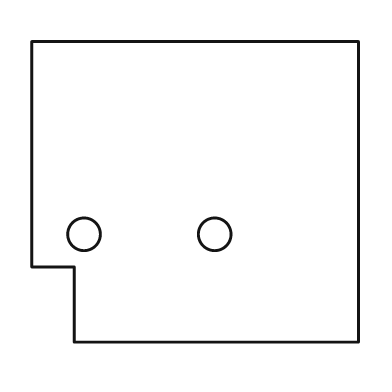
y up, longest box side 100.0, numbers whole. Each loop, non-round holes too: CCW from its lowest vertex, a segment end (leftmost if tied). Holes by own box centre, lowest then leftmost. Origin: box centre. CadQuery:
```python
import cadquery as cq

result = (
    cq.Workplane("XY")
    .moveTo(-37.0, -46.0)
    .lineTo(50.0, -46.0)
    .lineTo(50.0, 46.0)
    .lineTo(-50.0, 46.0)
    .lineTo(-50.0, -23.0)
    .lineTo(-37.0, -23.0)
    .close()
    .moveTo(-34.0, -13.0)
    .circle(5.0)
    .moveTo(6.0, -13.0)
    .circle(5.0)
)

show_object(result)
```